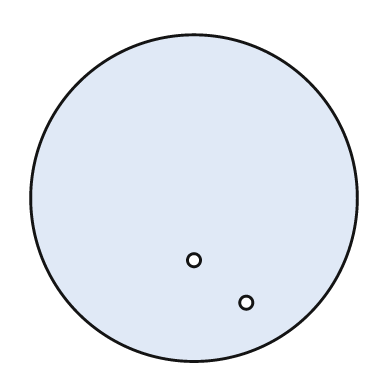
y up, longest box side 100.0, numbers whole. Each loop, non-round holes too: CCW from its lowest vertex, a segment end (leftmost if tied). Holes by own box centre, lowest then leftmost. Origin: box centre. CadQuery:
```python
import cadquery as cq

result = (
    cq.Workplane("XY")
    .moveTo(0.0, 0.0)
    .circle(50.0)
    .moveTo(16.0, -32.0)
    .circle(2.0)
    .moveTo(0.0, -19.0)
    .circle(2.0)
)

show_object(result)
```